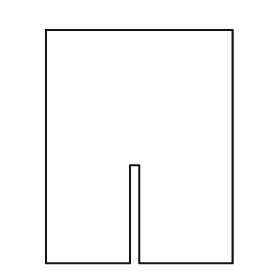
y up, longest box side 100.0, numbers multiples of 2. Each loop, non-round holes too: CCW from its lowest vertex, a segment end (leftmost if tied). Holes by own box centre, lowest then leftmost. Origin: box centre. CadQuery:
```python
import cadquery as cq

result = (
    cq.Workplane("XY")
    .moveTo(-40.0, -50.0)
    .lineTo(-4.0, -50.0)
    .lineTo(-4.0, -8.0)
    .lineTo(0.0, -8.0)
    .lineTo(0.0, -50.0)
    .lineTo(40.0, -50.0)
    .lineTo(40.0, 50.0)
    .lineTo(-40.0, 50.0)
    .close()
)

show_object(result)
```